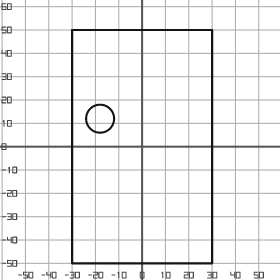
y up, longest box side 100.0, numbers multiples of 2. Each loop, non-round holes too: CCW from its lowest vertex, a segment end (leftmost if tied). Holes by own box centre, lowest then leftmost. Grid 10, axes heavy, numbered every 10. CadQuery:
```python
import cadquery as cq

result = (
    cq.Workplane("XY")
    .moveTo(-30.0, -50.0)
    .lineTo(30.0, -50.0)
    .lineTo(30.0, 50.0)
    .lineTo(-30.0, 50.0)
    .close()
    .moveTo(-18.0, 12.0)
    .circle(6.0)
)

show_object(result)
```